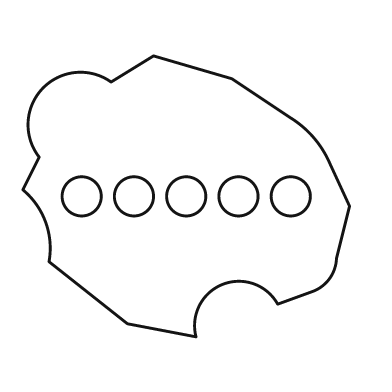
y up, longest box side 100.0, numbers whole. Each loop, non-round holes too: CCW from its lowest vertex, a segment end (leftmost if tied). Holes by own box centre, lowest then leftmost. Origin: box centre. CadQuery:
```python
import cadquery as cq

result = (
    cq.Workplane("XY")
    .moveTo(3.0, -43.0)
    .threePointArc((11.0, -27.0), (28.0, -33.0))
    .lineTo(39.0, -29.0)
    .threePointArc((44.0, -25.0), (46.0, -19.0))
    .lineTo(50.0, -3.0)
    .lineTo(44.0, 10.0)
    .threePointArc((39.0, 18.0), (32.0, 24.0))
    .lineTo(14.0, 36.0)
    .lineTo(-10.0, 43.0)
    .lineTo(-23.0, 35.0)
    .threePointArc((-44.0, 33.0), (-45.0, 12.0))
    .lineTo(-50.0, 2.0)
    .threePointArc((-43.0, -8.0), (-42.0, -20.0))
    .lineTo(-18.0, -39.0)
    .close()
    .moveTo(-32.0, 0.0)
    .circle(6.0)
    .moveTo(-16.0, 0.0)
    .circle(6.0)
    .moveTo(0.0, 0.0)
    .circle(6.0)
    .moveTo(16.0, 0.0)
    .circle(6.0)
    .moveTo(32.0, 0.0)
    .circle(6.0)
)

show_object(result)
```